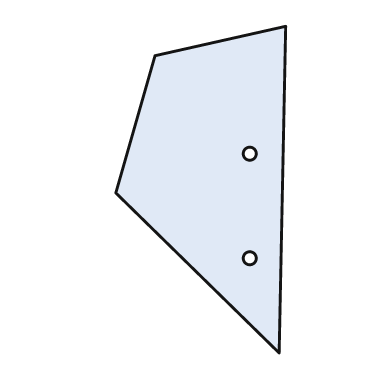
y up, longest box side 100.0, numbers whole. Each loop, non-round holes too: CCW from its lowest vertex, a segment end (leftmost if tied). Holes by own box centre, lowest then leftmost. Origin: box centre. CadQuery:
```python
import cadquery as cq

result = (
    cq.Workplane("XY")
    .moveTo(24.0, -50.0)
    .lineTo(26.0, 50.0)
    .lineTo(-14.0, 41.0)
    .lineTo(-26.0, -1.0)
    .close()
    .moveTo(15.0, -21.0)
    .circle(2.0)
    .moveTo(15.0, 11.0)
    .circle(2.0)
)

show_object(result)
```